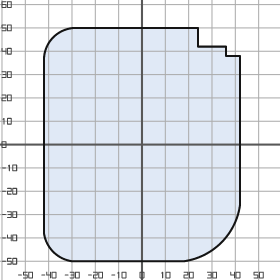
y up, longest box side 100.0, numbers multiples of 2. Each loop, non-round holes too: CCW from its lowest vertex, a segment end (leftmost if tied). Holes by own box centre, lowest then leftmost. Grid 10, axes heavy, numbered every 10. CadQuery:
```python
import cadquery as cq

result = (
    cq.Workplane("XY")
    .moveTo(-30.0, -50.0)
    .lineTo(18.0, -50.0)
    .threePointArc((34.0, -42.0), (42.0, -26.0))
    .lineTo(42.0, 38.0)
    .lineTo(36.0, 38.0)
    .lineTo(36.0, 42.0)
    .lineTo(24.0, 42.0)
    .lineTo(24.0, 50.0)
    .lineTo(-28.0, 50.0)
    .threePointArc((-38.0, 46.0), (-42.0, 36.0))
    .lineTo(-42.0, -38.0)
    .threePointArc((-38.0, -46.0), (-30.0, -50.0))
    .close()
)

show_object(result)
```